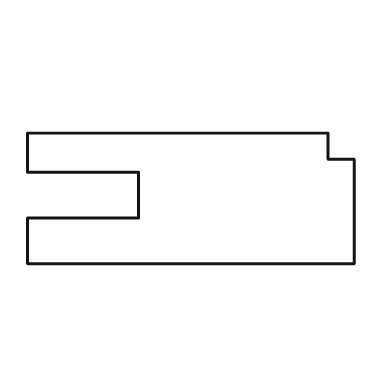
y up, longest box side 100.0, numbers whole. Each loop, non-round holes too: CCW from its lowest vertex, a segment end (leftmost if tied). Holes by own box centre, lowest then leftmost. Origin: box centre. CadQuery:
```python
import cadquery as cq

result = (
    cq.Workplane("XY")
    .moveTo(-50.0, -20.0)
    .lineTo(50.0, -20.0)
    .lineTo(50.0, 12.0)
    .lineTo(42.0, 12.0)
    .lineTo(42.0, 20.0)
    .lineTo(-50.0, 20.0)
    .lineTo(-50.0, 8.0)
    .lineTo(-16.0, 8.0)
    .lineTo(-16.0, -6.0)
    .lineTo(-50.0, -6.0)
    .close()
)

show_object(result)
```